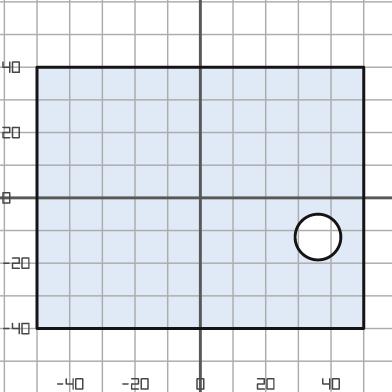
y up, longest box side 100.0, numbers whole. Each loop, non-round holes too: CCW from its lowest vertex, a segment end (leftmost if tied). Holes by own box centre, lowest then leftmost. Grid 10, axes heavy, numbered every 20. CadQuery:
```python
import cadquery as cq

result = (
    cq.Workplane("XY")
    .moveTo(-50.0, -40.0)
    .lineTo(50.0, -40.0)
    .lineTo(50.0, 40.0)
    .lineTo(-50.0, 40.0)
    .close()
    .moveTo(36.0, -12.0)
    .circle(7.0)
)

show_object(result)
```